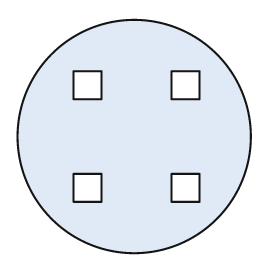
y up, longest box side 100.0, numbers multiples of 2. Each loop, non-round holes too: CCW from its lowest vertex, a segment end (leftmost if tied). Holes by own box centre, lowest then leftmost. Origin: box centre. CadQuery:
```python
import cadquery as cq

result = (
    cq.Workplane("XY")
    .moveTo(0.0, 0.0)
    .circle(50.0)
    .moveTo(-26.0, -28.0)
    .lineTo(-14.0, -28.0)
    .lineTo(-14.0, -16.0)
    .lineTo(-26.0, -16.0)
    .close()
    .moveTo(16.0, -28.0)
    .lineTo(28.0, -28.0)
    .lineTo(28.0, -16.0)
    .lineTo(16.0, -16.0)
    .close()
    .moveTo(-26.0, 16.0)
    .lineTo(-14.0, 16.0)
    .lineTo(-14.0, 28.0)
    .lineTo(-26.0, 28.0)
    .close()
    .moveTo(16.0, 16.0)
    .lineTo(28.0, 16.0)
    .lineTo(28.0, 28.0)
    .lineTo(16.0, 28.0)
    .close()
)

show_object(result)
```